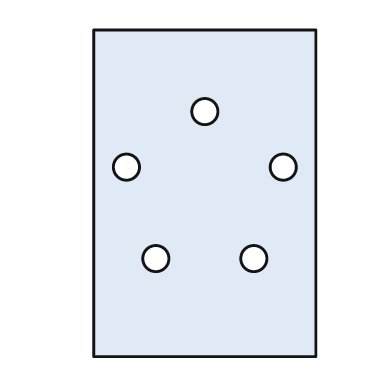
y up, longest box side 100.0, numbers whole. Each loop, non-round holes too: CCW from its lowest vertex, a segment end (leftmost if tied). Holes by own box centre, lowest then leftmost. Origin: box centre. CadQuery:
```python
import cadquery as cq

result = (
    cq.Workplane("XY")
    .moveTo(-34.0, -50.0)
    .lineTo(34.0, -50.0)
    .lineTo(34.0, 50.0)
    .lineTo(-34.0, 50.0)
    .close()
    .moveTo(-15.0, -20.0)
    .circle(4.0)
    .moveTo(15.0, -20.0)
    .circle(4.0)
    .moveTo(-24.0, 8.0)
    .circle(4.0)
    .moveTo(24.0, 8.0)
    .circle(4.0)
    .moveTo(0.0, 25.0)
    .circle(4.0)
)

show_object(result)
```